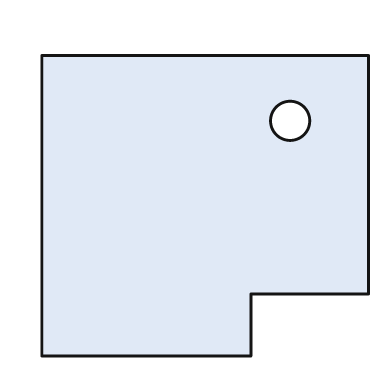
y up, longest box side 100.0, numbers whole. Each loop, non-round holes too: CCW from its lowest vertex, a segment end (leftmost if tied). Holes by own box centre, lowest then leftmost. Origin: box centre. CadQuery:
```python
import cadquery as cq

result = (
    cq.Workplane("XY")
    .moveTo(-50.0, -46.0)
    .lineTo(14.0, -46.0)
    .lineTo(14.0, -27.0)
    .lineTo(50.0, -27.0)
    .lineTo(50.0, 46.0)
    .lineTo(-50.0, 46.0)
    .close()
    .moveTo(26.0, 26.0)
    .circle(6.0)
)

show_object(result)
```